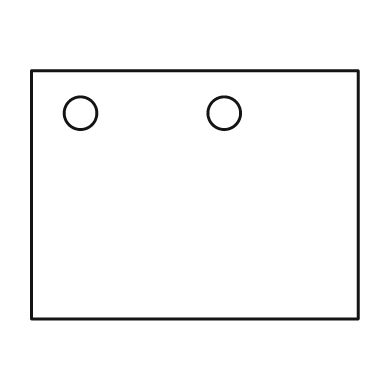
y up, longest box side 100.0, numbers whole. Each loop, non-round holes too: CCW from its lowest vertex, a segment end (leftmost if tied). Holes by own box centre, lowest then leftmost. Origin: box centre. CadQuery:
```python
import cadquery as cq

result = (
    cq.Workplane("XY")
    .moveTo(-50.0, -38.0)
    .lineTo(50.0, -38.0)
    .lineTo(50.0, 38.0)
    .lineTo(-50.0, 38.0)
    .close()
    .moveTo(-35.0, 25.0)
    .circle(5.0)
    .moveTo(9.0, 25.0)
    .circle(5.0)
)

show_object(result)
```